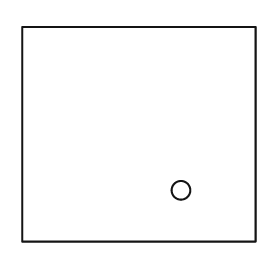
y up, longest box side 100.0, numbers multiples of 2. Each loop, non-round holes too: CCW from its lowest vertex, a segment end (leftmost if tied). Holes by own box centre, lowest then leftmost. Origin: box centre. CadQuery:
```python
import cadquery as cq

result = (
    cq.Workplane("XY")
    .moveTo(-50.0, -46.0)
    .lineTo(50.0, -46.0)
    .lineTo(50.0, 46.0)
    .lineTo(-50.0, 46.0)
    .close()
    .moveTo(18.0, -24.0)
    .circle(4.0)
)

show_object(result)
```